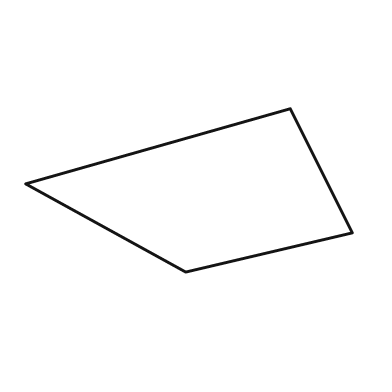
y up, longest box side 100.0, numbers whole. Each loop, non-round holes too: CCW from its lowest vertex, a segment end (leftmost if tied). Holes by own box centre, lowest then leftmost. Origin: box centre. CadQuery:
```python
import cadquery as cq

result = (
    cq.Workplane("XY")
    .moveTo(-1.0, -25.0)
    .lineTo(50.0, -13.0)
    .lineTo(31.0, 25.0)
    .lineTo(-50.0, 2.0)
    .close()
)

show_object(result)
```